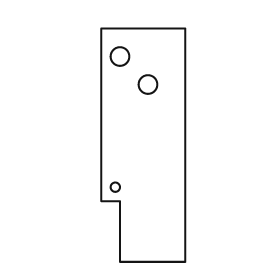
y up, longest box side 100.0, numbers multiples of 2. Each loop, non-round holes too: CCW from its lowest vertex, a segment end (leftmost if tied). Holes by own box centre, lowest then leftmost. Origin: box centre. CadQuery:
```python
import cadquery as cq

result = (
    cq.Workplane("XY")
    .moveTo(-10.0, -50.0)
    .lineTo(18.0, -50.0)
    .lineTo(18.0, 50.0)
    .lineTo(-18.0, 50.0)
    .lineTo(-18.0, -24.0)
    .lineTo(-10.0, -24.0)
    .close()
    .moveTo(-12.0, -18.0)
    .circle(2.0)
    .moveTo(2.0, 26.0)
    .circle(4.0)
    .moveTo(-10.0, 38.0)
    .circle(4.0)
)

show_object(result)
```